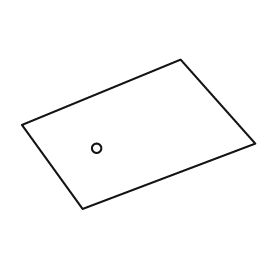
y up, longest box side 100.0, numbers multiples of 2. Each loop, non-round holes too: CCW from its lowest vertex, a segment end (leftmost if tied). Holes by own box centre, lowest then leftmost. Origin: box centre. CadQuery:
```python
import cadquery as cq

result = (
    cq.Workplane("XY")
    .moveTo(-24.0, -32.0)
    .lineTo(50.0, -4.0)
    .lineTo(18.0, 32.0)
    .lineTo(-50.0, 4.0)
    .close()
    .moveTo(-18.0, -6.0)
    .circle(2.0)
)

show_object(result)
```